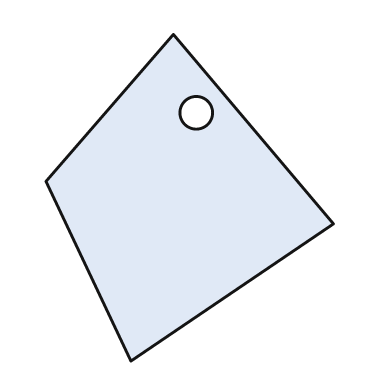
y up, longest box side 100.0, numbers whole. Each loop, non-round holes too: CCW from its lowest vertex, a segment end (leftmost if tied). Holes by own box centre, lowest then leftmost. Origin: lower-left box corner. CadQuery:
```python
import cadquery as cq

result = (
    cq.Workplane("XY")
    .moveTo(26.0, 0.0)
    .lineTo(88.0, 42.0)
    .lineTo(39.0, 100.0)
    .lineTo(0.0, 55.0)
    .close()
    .moveTo(46.0, 76.0)
    .circle(5.0)
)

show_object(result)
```